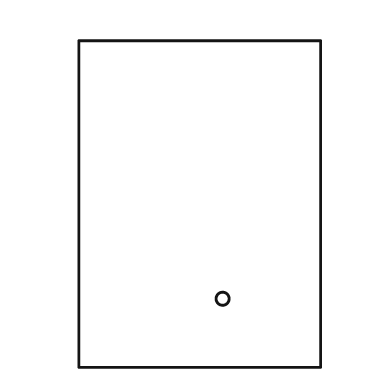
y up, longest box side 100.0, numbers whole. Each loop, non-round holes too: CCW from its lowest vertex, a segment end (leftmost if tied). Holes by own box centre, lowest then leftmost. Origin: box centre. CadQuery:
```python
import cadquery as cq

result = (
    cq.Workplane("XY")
    .moveTo(-37.0, -50.0)
    .lineTo(37.0, -50.0)
    .lineTo(37.0, 50.0)
    .lineTo(-37.0, 50.0)
    .close()
    .moveTo(7.0, -29.0)
    .circle(2.0)
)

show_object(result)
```